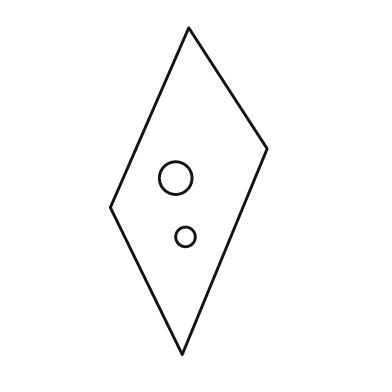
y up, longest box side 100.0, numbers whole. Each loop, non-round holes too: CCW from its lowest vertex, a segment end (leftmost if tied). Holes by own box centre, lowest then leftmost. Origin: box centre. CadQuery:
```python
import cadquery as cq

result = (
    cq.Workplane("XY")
    .moveTo(-2.0, -50.0)
    .lineTo(24.0, 13.0)
    .lineTo(0.0, 50.0)
    .lineTo(-24.0, -5.0)
    .close()
    .moveTo(-1.0, -14.0)
    .circle(3.0)
    .moveTo(-4.0, 4.0)
    .circle(5.0)
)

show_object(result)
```